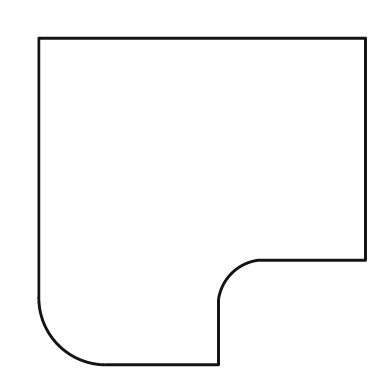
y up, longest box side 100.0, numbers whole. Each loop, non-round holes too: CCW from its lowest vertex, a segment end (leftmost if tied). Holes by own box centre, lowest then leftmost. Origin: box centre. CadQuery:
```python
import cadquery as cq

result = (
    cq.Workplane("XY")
    .moveTo(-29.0, -50.0)
    .lineTo(5.0, -50.0)
    .lineTo(5.0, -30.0)
    .threePointArc((9.0, -22.0), (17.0, -18.0))
    .lineTo(50.0, -18.0)
    .lineTo(50.0, 50.0)
    .lineTo(-50.0, 50.0)
    .lineTo(-50.0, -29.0)
    .threePointArc((-44.0, -44.0), (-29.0, -50.0))
    .close()
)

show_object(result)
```